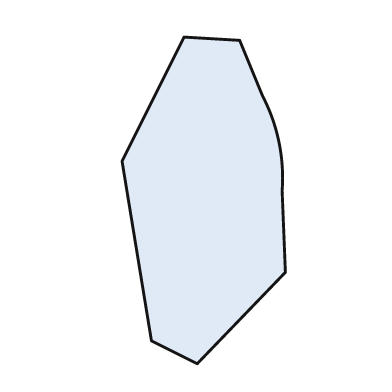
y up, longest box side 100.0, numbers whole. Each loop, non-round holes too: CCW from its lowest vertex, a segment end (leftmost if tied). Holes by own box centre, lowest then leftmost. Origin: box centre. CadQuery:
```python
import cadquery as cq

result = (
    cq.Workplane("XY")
    .moveTo(-2.0, -50.0)
    .lineTo(25.0, -22.0)
    .lineTo(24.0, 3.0)
    .threePointArc((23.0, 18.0), (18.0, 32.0))
    .lineTo(11.0, 49.0)
    .lineTo(-6.0, 50.0)
    .lineTo(-25.0, 12.0)
    .lineTo(-16.0, -43.0)
    .close()
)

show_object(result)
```